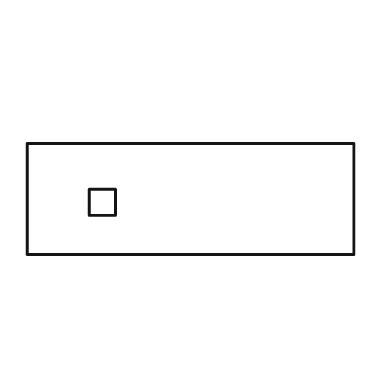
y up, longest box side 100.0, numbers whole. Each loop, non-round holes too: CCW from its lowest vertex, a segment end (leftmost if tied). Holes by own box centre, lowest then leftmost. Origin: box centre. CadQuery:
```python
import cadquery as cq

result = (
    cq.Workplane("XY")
    .moveTo(-50.0, -17.0)
    .lineTo(50.0, -17.0)
    .lineTo(50.0, 17.0)
    .lineTo(-50.0, 17.0)
    .close()
    .moveTo(-31.0, -5.0)
    .lineTo(-23.0, -5.0)
    .lineTo(-23.0, 3.0)
    .lineTo(-31.0, 3.0)
    .close()
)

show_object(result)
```